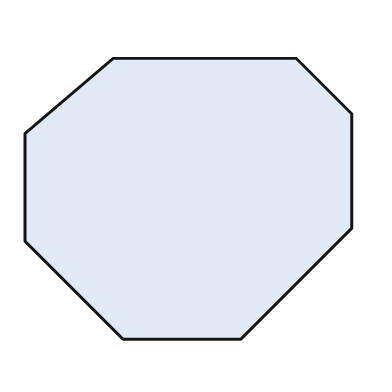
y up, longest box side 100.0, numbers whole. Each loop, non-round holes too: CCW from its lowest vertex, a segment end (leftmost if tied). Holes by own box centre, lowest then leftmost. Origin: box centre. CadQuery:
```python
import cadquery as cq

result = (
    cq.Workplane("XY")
    .moveTo(-20.0, -43.0)
    .lineTo(16.0, -43.0)
    .lineTo(50.0, -9.0)
    .lineTo(50.0, 26.0)
    .lineTo(33.0, 43.0)
    .lineTo(-23.0, 43.0)
    .lineTo(-50.0, 20.0)
    .lineTo(-50.0, -13.0)
    .close()
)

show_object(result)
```